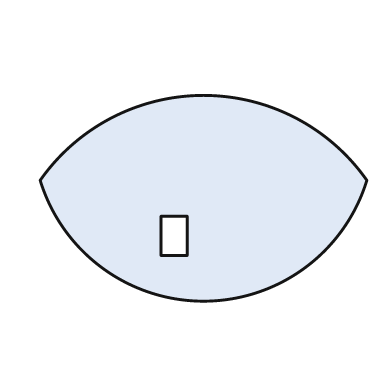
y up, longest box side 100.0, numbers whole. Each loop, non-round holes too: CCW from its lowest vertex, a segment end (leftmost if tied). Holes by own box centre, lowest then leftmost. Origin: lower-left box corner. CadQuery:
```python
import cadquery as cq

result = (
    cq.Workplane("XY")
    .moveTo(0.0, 37.0)
    .threePointArc((50.0, 0.0), (100.0, 37.0))
    .threePointArc((50.0, 63.0), (0.0, 37.0))
    .close()
    .moveTo(37.0, 14.0)
    .lineTo(45.0, 14.0)
    .lineTo(45.0, 26.0)
    .lineTo(37.0, 26.0)
    .close()
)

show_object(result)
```